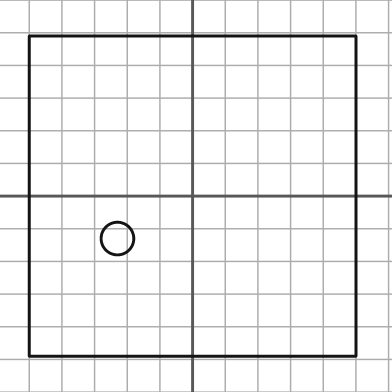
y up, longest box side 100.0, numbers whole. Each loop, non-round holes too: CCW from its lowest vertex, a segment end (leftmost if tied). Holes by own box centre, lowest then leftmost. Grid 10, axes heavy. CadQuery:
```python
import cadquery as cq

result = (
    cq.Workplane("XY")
    .moveTo(-50.0, -49.0)
    .lineTo(50.0, -49.0)
    .lineTo(50.0, 49.0)
    .lineTo(-50.0, 49.0)
    .close()
    .moveTo(-23.0, -13.0)
    .circle(5.0)
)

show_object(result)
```